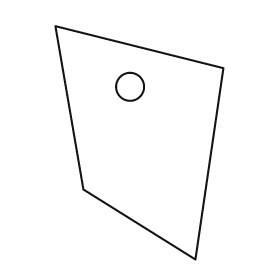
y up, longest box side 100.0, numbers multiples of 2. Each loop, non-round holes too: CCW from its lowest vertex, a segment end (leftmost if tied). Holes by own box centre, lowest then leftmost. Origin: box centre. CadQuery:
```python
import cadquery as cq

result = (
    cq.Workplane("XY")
    .moveTo(24.0, -50.0)
    .lineTo(36.0, 32.0)
    .lineTo(-36.0, 50.0)
    .lineTo(-24.0, -20.0)
    .close()
    .moveTo(-4.0, 24.0)
    .circle(6.0)
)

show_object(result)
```